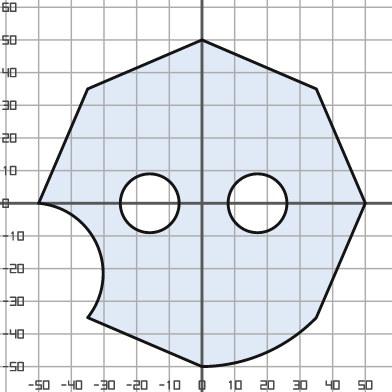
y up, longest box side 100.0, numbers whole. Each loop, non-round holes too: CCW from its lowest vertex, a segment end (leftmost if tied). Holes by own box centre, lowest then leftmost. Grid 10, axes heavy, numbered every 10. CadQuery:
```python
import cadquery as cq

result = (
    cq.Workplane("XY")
    .moveTo(0.0, -50.0)
    .threePointArc((19.0, -46.0), (35.0, -35.0))
    .lineTo(50.0, 0.0)
    .lineTo(35.0, 35.0)
    .lineTo(0.0, 50.0)
    .lineTo(-35.0, 35.0)
    .lineTo(-50.0, 0.0)
    .threePointArc((-32.0, -13.0), (-35.0, -35.0))
    .close()
    .moveTo(-16.0, 0.0)
    .circle(9.0)
    .moveTo(17.0, 0.0)
    .circle(9.0)
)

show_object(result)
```